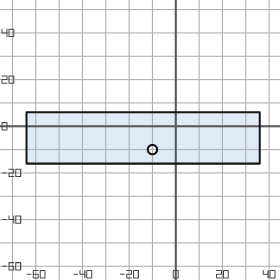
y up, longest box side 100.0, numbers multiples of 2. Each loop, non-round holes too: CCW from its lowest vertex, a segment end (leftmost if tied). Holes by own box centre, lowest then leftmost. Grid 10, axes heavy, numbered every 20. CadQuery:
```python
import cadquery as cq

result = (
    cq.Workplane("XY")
    .moveTo(-64.0, -16.0)
    .lineTo(36.0, -16.0)
    .lineTo(36.0, 6.0)
    .lineTo(-64.0, 6.0)
    .close()
    .moveTo(-10.0, -10.0)
    .circle(2.0)
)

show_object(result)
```